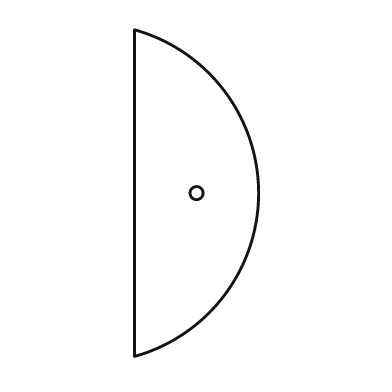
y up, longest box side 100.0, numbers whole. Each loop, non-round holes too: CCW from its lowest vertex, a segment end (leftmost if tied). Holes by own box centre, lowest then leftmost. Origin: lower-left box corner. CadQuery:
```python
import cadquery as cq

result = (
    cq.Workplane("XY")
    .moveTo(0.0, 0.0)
    .threePointArc((38.0, 50.0), (0.0, 100.0))
    .close()
    .moveTo(19.0, 50.0)
    .circle(2.0)
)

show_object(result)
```